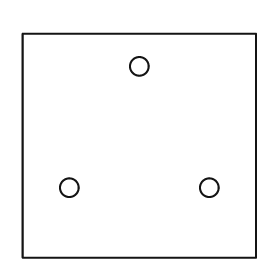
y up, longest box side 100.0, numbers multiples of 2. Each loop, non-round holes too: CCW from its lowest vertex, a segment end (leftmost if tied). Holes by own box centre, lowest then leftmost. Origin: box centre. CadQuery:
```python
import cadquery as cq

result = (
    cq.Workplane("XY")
    .moveTo(-50.0, -48.0)
    .lineTo(50.0, -48.0)
    .lineTo(50.0, 48.0)
    .lineTo(-50.0, 48.0)
    .close()
    .moveTo(-30.0, -18.0)
    .circle(4.0)
    .moveTo(30.0, -18.0)
    .circle(4.0)
    .moveTo(0.0, 34.0)
    .circle(4.0)
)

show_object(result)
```